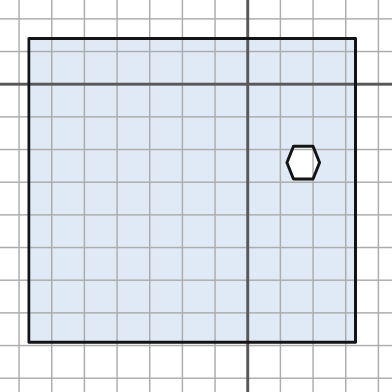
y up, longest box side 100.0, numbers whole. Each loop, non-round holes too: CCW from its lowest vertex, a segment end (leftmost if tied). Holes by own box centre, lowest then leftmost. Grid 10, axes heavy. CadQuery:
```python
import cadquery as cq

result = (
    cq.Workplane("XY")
    .moveTo(-67.0, -79.0)
    .lineTo(33.0, -79.0)
    .lineTo(33.0, 14.0)
    .lineTo(-67.0, 14.0)
    .close()
    .moveTo(14.0, -29.0)
    .lineTo(20.0, -29.0)
    .lineTo(22.0, -24.0)
    .lineTo(20.0, -19.0)
    .lineTo(14.0, -19.0)
    .lineTo(12.0, -24.0)
    .close()
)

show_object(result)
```